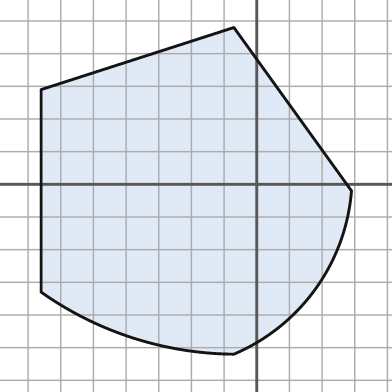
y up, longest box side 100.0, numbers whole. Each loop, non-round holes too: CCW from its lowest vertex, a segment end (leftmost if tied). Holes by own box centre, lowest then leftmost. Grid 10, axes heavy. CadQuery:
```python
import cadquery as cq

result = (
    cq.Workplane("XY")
    .moveTo(-7.0, -52.0)
    .threePointArc((18.0, -32.0), (29.0, -2.0))
    .lineTo(-7.0, 48.0)
    .lineTo(-66.0, 29.0)
    .lineTo(-66.0, -33.0)
    .threePointArc((-38.0, -47.0), (-7.0, -52.0))
    .close()
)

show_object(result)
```